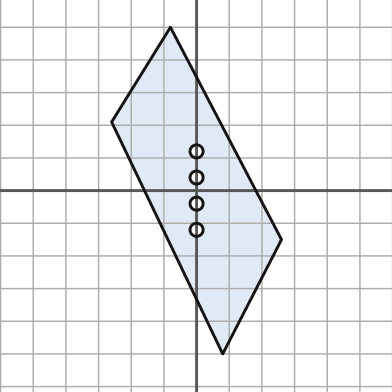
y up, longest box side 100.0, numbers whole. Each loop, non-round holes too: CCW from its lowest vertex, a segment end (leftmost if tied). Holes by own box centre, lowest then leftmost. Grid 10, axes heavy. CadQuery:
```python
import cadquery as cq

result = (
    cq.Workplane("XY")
    .moveTo(8.0, -50.0)
    .lineTo(26.0, -15.0)
    .lineTo(-8.0, 50.0)
    .lineTo(-26.0, 21.0)
    .close()
    .moveTo(0.0, -12.0)
    .circle(2.0)
    .moveTo(0.0, -4.0)
    .circle(2.0)
    .moveTo(0.0, 4.0)
    .circle(2.0)
    .moveTo(0.0, 12.0)
    .circle(2.0)
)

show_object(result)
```